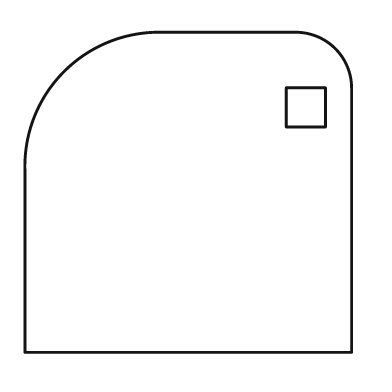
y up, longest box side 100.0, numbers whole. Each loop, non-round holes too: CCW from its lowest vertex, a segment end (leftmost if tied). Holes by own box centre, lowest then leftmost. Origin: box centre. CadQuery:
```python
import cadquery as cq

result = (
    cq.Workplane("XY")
    .moveTo(-50.0, -49.0)
    .lineTo(50.0, -49.0)
    .lineTo(50.0, 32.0)
    .threePointArc((45.0, 44.0), (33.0, 49.0))
    .lineTo(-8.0, 49.0)
    .threePointArc((-38.0, 37.0), (-50.0, 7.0))
    .close()
    .moveTo(30.0, 20.0)
    .lineTo(42.0, 20.0)
    .lineTo(42.0, 32.0)
    .lineTo(30.0, 32.0)
    .close()
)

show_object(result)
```